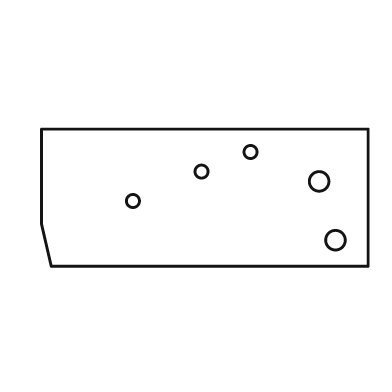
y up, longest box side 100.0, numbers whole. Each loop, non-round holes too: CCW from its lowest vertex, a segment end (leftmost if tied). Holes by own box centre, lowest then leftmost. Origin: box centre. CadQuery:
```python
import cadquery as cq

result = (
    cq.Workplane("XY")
    .moveTo(-47.0, -21.0)
    .lineTo(50.0, -21.0)
    .lineTo(50.0, 21.0)
    .lineTo(-50.0, 21.0)
    .lineTo(-50.0, -8.0)
    .close()
    .moveTo(40.0, -13.0)
    .circle(3.0)
    .moveTo(-22.0, -1.0)
    .circle(2.0)
    .moveTo(35.0, 5.0)
    .circle(3.0)
    .moveTo(-1.0, 8.0)
    .circle(2.0)
    .moveTo(14.0, 14.0)
    .circle(2.0)
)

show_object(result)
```